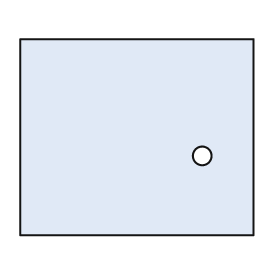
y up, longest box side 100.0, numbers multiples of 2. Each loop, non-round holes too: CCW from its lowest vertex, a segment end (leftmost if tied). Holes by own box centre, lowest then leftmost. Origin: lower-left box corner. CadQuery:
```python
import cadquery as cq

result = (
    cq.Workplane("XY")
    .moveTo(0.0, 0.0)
    .lineTo(100.0, 0.0)
    .lineTo(100.0, 84.0)
    .lineTo(0.0, 84.0)
    .close()
    .moveTo(78.0, 34.0)
    .circle(4.0)
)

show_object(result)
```